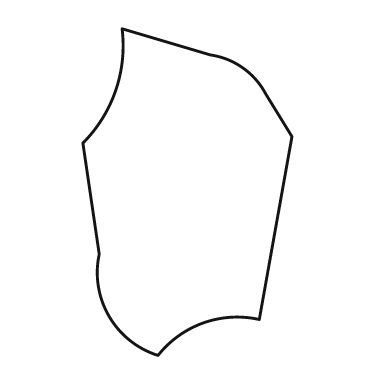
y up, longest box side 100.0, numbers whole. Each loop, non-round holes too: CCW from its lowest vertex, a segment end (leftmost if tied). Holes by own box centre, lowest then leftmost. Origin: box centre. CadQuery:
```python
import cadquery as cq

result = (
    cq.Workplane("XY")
    .moveTo(-9.0, -50.0)
    .threePointArc((5.0, -40.0), (22.0, -39.0))
    .lineTo(32.0, 17.0)
    .lineTo(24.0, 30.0)
    .threePointArc((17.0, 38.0), (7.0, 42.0))
    .lineTo(-20.0, 50.0)
    .threePointArc((-22.0, 31.0), (-32.0, 15.0))
    .lineTo(-27.0, -19.0)
    .threePointArc((-24.0, -38.0), (-9.0, -50.0))
    .close()
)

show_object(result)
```